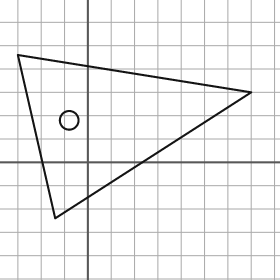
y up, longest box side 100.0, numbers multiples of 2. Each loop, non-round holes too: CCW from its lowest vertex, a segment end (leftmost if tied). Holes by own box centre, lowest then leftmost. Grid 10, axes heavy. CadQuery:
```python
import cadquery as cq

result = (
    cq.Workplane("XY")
    .moveTo(-14.0, -24.0)
    .lineTo(70.0, 30.0)
    .lineTo(-30.0, 46.0)
    .close()
    .moveTo(-8.0, 18.0)
    .circle(4.0)
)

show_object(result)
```